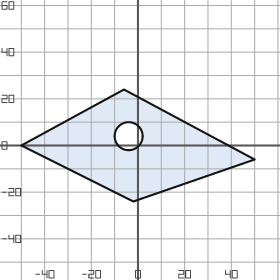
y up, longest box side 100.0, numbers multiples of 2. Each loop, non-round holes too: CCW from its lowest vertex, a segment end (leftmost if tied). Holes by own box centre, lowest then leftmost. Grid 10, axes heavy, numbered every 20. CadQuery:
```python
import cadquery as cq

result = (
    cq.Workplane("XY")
    .moveTo(-2.0, -24.0)
    .lineTo(50.0, -6.0)
    .lineTo(-6.0, 24.0)
    .lineTo(-50.0, 0.0)
    .close()
    .moveTo(-4.0, 4.0)
    .circle(6.0)
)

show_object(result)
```